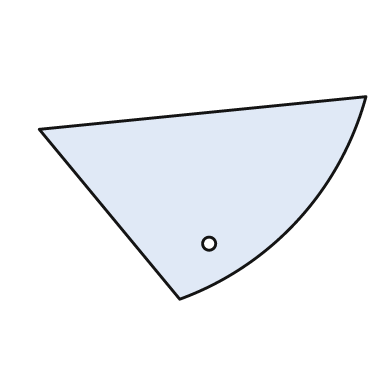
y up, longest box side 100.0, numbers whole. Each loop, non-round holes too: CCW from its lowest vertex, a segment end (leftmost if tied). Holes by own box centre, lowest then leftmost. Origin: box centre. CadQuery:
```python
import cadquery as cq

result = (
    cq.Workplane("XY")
    .moveTo(-7.0, -31.0)
    .threePointArc((29.0, -7.0), (50.0, 31.0))
    .lineTo(-50.0, 21.0)
    .close()
    .moveTo(2.0, -14.0)
    .circle(2.0)
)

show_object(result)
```